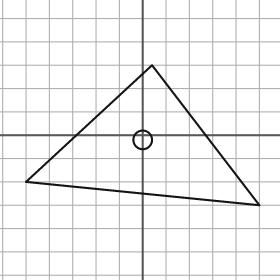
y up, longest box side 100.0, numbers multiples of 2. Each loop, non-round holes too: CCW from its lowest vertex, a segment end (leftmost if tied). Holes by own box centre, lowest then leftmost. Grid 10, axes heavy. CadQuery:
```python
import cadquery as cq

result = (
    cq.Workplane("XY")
    .moveTo(50.0, -30.0)
    .lineTo(4.0, 30.0)
    .lineTo(-50.0, -20.0)
    .close()
    .moveTo(0.0, -2.0)
    .circle(4.0)
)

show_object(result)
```